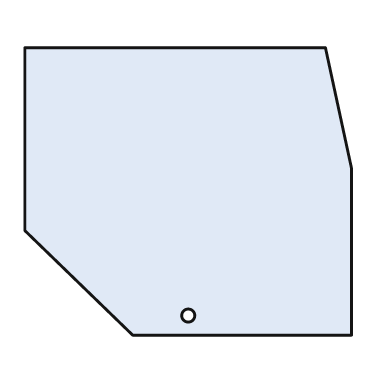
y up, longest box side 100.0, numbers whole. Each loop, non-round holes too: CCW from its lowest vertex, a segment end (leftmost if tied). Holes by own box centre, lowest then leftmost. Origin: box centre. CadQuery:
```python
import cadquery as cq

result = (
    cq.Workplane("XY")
    .moveTo(-17.0, -44.0)
    .lineTo(50.0, -44.0)
    .lineTo(50.0, 7.0)
    .lineTo(42.0, 44.0)
    .lineTo(-50.0, 44.0)
    .lineTo(-50.0, -12.0)
    .close()
    .moveTo(0.0, -38.0)
    .circle(2.0)
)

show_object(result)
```